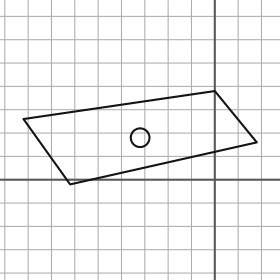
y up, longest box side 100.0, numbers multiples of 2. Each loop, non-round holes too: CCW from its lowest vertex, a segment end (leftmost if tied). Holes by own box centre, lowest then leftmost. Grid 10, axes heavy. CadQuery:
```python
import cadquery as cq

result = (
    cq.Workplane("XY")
    .moveTo(-62.0, -2.0)
    .lineTo(18.0, 16.0)
    .lineTo(0.0, 38.0)
    .lineTo(-82.0, 26.0)
    .close()
    .moveTo(-32.0, 18.0)
    .circle(4.0)
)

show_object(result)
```